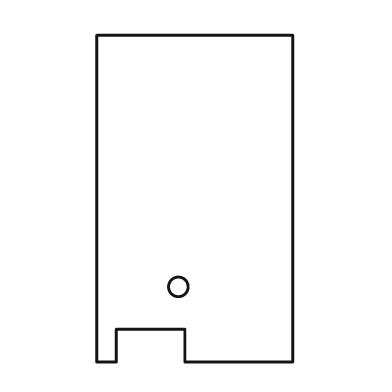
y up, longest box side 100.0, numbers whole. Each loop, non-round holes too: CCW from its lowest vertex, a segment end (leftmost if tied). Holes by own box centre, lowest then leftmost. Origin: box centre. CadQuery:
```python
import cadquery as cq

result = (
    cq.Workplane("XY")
    .moveTo(-30.0, -50.0)
    .lineTo(-24.0, -50.0)
    .lineTo(-24.0, -40.0)
    .lineTo(-3.0, -40.0)
    .lineTo(-3.0, -50.0)
    .lineTo(30.0, -50.0)
    .lineTo(30.0, 50.0)
    .lineTo(-30.0, 50.0)
    .close()
    .moveTo(-5.0, -27.0)
    .circle(3.0)
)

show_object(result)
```